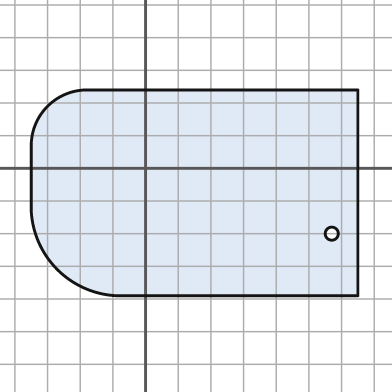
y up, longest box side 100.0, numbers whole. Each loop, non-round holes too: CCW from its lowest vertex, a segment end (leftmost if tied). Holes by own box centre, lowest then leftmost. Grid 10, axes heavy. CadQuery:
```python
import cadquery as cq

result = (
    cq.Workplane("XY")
    .moveTo(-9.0, -39.0)
    .lineTo(65.0, -39.0)
    .lineTo(65.0, 24.0)
    .lineTo(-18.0, 24.0)
    .threePointArc((-30.0, 19.0), (-35.0, 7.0))
    .lineTo(-35.0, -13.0)
    .threePointArc((-27.0, -31.0), (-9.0, -39.0))
    .close()
    .moveTo(57.0, -20.0)
    .circle(2.0)
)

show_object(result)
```